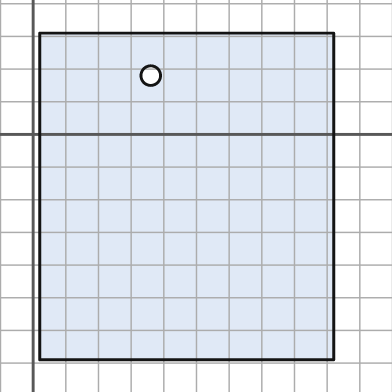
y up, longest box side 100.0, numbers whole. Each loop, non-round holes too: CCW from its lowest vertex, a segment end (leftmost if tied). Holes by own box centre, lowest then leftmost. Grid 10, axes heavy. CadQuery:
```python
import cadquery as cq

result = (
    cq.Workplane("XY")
    .moveTo(2.0, -69.0)
    .lineTo(92.0, -69.0)
    .lineTo(92.0, 31.0)
    .lineTo(2.0, 31.0)
    .close()
    .moveTo(36.0, 18.0)
    .circle(3.0)
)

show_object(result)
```